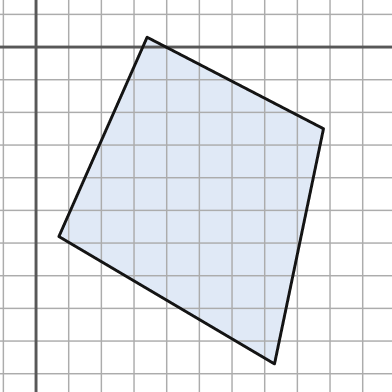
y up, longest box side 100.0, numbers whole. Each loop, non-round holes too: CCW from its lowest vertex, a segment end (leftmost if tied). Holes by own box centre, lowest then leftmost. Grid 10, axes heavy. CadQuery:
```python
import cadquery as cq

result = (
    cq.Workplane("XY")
    .moveTo(73.0, -97.0)
    .lineTo(88.0, -25.0)
    .lineTo(34.0, 3.0)
    .lineTo(7.0, -58.0)
    .close()
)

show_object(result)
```